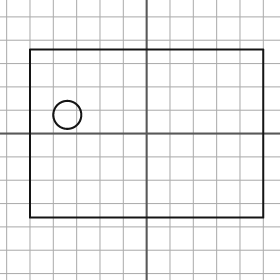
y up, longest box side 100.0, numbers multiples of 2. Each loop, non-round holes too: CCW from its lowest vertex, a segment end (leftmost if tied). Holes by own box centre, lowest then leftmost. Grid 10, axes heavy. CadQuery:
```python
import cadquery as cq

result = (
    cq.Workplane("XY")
    .moveTo(-50.0, -36.0)
    .lineTo(50.0, -36.0)
    .lineTo(50.0, 36.0)
    .lineTo(-50.0, 36.0)
    .close()
    .moveTo(-34.0, 8.0)
    .circle(6.0)
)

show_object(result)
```